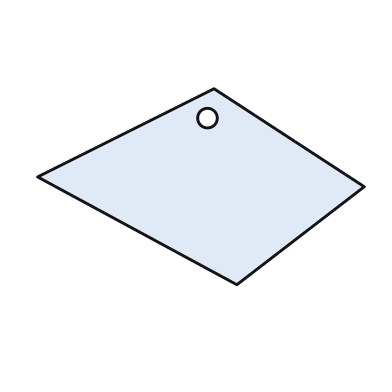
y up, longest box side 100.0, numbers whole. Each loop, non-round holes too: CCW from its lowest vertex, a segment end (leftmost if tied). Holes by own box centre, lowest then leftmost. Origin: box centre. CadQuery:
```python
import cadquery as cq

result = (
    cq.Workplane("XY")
    .moveTo(11.0, -30.0)
    .lineTo(50.0, 0.0)
    .lineTo(4.0, 30.0)
    .lineTo(-50.0, 3.0)
    .close()
    .moveTo(2.0, 21.0)
    .circle(3.0)
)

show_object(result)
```